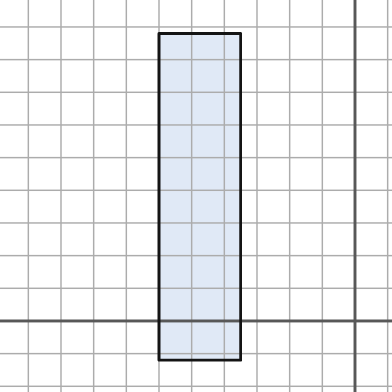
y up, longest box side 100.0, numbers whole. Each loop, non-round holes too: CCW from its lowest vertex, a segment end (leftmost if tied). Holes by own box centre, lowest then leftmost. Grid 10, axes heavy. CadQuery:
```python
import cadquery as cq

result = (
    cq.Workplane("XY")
    .moveTo(-60.0, -12.0)
    .lineTo(-35.0, -12.0)
    .lineTo(-35.0, 88.0)
    .lineTo(-60.0, 88.0)
    .close()
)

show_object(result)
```